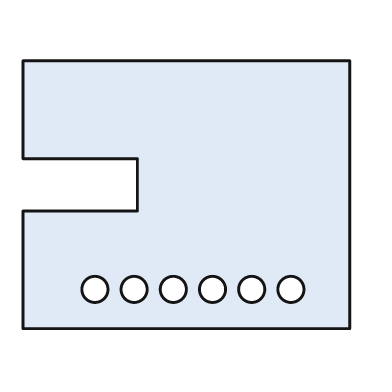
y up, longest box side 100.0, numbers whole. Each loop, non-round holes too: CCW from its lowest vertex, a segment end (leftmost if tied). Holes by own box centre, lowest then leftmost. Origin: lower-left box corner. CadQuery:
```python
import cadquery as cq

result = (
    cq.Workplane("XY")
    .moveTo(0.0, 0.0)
    .lineTo(100.0, 0.0)
    .lineTo(100.0, 82.0)
    .lineTo(0.0, 82.0)
    .lineTo(0.0, 52.0)
    .lineTo(35.0, 52.0)
    .lineTo(35.0, 36.0)
    .lineTo(0.0, 36.0)
    .close()
    .moveTo(22.0, 12.0)
    .circle(4.0)
    .moveTo(34.0, 12.0)
    .circle(4.0)
    .moveTo(46.0, 12.0)
    .circle(4.0)
    .moveTo(58.0, 12.0)
    .circle(4.0)
    .moveTo(70.0, 12.0)
    .circle(4.0)
    .moveTo(82.0, 12.0)
    .circle(4.0)
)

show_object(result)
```